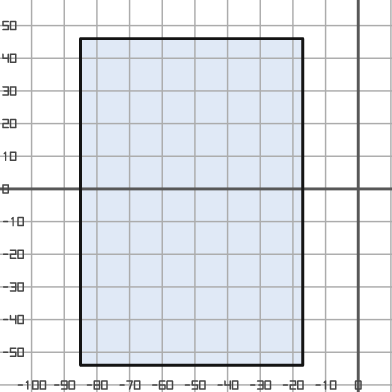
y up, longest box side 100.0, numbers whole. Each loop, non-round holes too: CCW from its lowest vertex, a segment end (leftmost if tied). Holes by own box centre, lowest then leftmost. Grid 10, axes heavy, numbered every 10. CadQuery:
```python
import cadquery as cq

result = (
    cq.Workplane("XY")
    .moveTo(-85.0, -54.0)
    .lineTo(-17.0, -54.0)
    .lineTo(-17.0, 46.0)
    .lineTo(-85.0, 46.0)
    .close()
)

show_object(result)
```